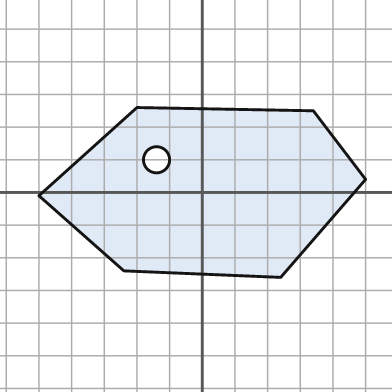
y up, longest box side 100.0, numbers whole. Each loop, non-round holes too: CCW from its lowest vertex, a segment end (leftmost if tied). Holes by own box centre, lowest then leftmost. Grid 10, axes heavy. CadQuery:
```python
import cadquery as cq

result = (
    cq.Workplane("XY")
    .moveTo(24.0, -26.0)
    .lineTo(50.0, 4.0)
    .lineTo(34.0, 25.0)
    .lineTo(-20.0, 26.0)
    .lineTo(-50.0, -1.0)
    .lineTo(-24.0, -24.0)
    .close()
    .moveTo(-14.0, 10.0)
    .circle(4.0)
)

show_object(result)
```